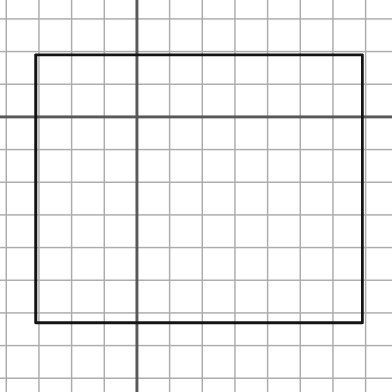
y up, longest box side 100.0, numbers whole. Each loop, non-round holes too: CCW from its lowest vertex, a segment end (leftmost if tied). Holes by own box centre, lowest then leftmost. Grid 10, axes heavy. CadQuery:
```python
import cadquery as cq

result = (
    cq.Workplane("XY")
    .moveTo(-31.0, -63.0)
    .lineTo(69.0, -63.0)
    .lineTo(69.0, 19.0)
    .lineTo(-31.0, 19.0)
    .close()
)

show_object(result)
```